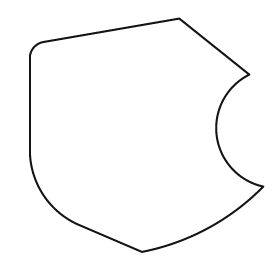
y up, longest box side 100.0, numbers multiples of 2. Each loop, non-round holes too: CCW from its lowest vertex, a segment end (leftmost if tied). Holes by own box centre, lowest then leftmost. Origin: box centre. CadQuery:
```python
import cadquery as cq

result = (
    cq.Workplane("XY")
    .moveTo(-2.0, -50.0)
    .threePointArc((26.0, -40.0), (50.0, -22.0))
    .threePointArc((30.0, 0.0), (44.0, 26.0))
    .lineTo(14.0, 50.0)
    .lineTo(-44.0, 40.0)
    .threePointArc((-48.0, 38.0), (-50.0, 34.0))
    .lineTo(-50.0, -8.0)
    .threePointArc((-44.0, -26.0), (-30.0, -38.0))
    .close()
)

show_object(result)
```